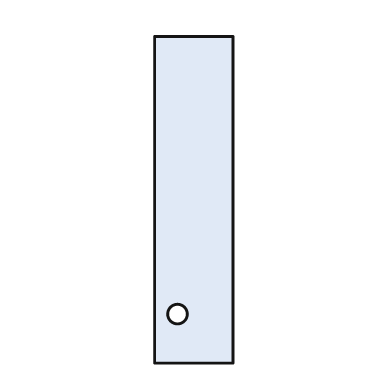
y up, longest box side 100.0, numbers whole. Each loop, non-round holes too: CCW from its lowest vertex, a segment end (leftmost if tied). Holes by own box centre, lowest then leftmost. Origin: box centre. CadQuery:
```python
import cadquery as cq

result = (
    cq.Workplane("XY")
    .moveTo(-12.0, -50.0)
    .lineTo(12.0, -50.0)
    .lineTo(12.0, 50.0)
    .lineTo(-12.0, 50.0)
    .close()
    .moveTo(-5.0, -35.0)
    .circle(3.0)
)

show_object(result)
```